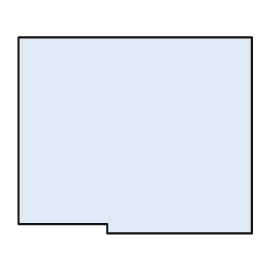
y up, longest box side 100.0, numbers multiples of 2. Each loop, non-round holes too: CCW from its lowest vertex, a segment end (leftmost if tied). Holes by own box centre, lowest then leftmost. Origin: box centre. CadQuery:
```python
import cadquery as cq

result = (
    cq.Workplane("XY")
    .moveTo(-12.0, -42.0)
    .lineTo(50.0, -42.0)
    .lineTo(50.0, 42.0)
    .lineTo(-50.0, 42.0)
    .lineTo(-50.0, -38.0)
    .lineTo(-12.0, -38.0)
    .close()
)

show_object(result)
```